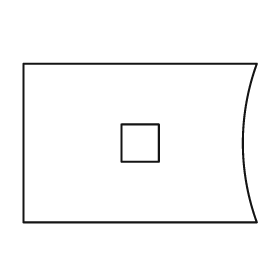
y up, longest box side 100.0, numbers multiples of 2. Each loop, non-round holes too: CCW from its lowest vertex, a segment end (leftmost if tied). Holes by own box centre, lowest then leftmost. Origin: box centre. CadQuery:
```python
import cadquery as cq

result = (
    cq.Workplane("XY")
    .moveTo(-50.0, -34.0)
    .lineTo(50.0, -34.0)
    .threePointArc((44.0, 0.0), (50.0, 34.0))
    .lineTo(-50.0, 34.0)
    .close()
    .moveTo(-8.0, -8.0)
    .lineTo(8.0, -8.0)
    .lineTo(8.0, 8.0)
    .lineTo(-8.0, 8.0)
    .close()
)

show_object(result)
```